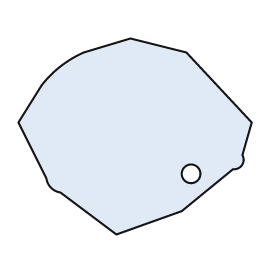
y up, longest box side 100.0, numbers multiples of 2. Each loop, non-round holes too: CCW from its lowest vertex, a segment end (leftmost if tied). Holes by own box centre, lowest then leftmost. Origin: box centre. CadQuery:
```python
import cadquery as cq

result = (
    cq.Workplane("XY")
    .moveTo(-8.0, -42.0)
    .lineTo(20.0, -32.0)
    .lineTo(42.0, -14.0)
    .threePointArc((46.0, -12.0), (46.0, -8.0))
    .lineTo(50.0, 6.0)
    .lineTo(22.0, 36.0)
    .lineTo(-2.0, 42.0)
    .lineTo(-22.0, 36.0)
    .threePointArc((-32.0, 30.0), (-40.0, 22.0))
    .lineTo(-50.0, 6.0)
    .lineTo(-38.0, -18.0)
    .threePointArc((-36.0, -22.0), (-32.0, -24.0))
    .close()
    .moveTo(24.0, -16.0)
    .circle(4.0)
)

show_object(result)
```